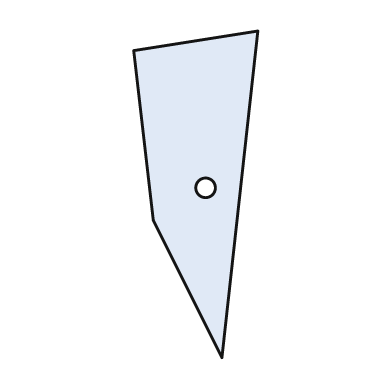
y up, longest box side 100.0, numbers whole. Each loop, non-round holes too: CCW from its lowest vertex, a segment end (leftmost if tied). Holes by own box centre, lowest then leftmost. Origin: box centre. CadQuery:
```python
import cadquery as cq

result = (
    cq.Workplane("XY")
    .moveTo(8.0, -50.0)
    .lineTo(19.0, 50.0)
    .lineTo(-19.0, 44.0)
    .lineTo(-13.0, -8.0)
    .close()
    .moveTo(3.0, 2.0)
    .circle(3.0)
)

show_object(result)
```